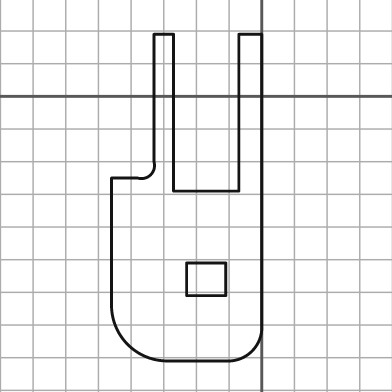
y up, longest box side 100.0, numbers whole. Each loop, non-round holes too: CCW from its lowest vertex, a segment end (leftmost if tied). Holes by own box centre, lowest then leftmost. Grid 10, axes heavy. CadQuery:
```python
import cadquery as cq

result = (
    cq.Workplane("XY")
    .moveTo(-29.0, -81.0)
    .lineTo(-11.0, -81.0)
    .threePointArc((-3.0, -78.0), (0.0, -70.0))
    .lineTo(0.0, 19.0)
    .lineTo(-7.0, 19.0)
    .lineTo(-7.0, -29.0)
    .lineTo(-27.0, -29.0)
    .lineTo(-27.0, 19.0)
    .lineTo(-33.0, 19.0)
    .lineTo(-33.0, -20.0)
    .threePointArc((-34.0, -24.0), (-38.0, -25.0))
    .lineTo(-46.0, -25.0)
    .lineTo(-46.0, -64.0)
    .threePointArc((-41.0, -76.0), (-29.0, -81.0))
    .close()
    .moveTo(-23.0, -61.0)
    .lineTo(-11.0, -61.0)
    .lineTo(-11.0, -51.0)
    .lineTo(-23.0, -51.0)
    .close()
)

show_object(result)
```